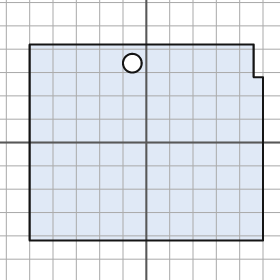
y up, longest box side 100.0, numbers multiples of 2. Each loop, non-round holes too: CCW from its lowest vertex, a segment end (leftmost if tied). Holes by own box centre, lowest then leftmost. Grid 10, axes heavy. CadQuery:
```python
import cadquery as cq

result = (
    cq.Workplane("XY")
    .moveTo(-50.0, -42.0)
    .lineTo(50.0, -42.0)
    .lineTo(50.0, 28.0)
    .lineTo(46.0, 28.0)
    .lineTo(46.0, 42.0)
    .lineTo(-50.0, 42.0)
    .close()
    .moveTo(-6.0, 34.0)
    .circle(4.0)
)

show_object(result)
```